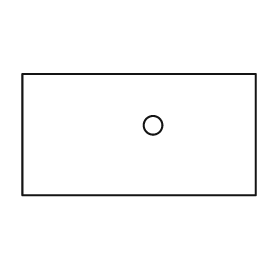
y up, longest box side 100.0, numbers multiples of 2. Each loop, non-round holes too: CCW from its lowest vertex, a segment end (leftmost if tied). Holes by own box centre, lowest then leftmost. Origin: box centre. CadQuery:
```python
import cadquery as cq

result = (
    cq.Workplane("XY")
    .moveTo(-50.0, -26.0)
    .lineTo(50.0, -26.0)
    .lineTo(50.0, 26.0)
    .lineTo(-50.0, 26.0)
    .close()
    .moveTo(6.0, 4.0)
    .circle(4.0)
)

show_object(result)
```